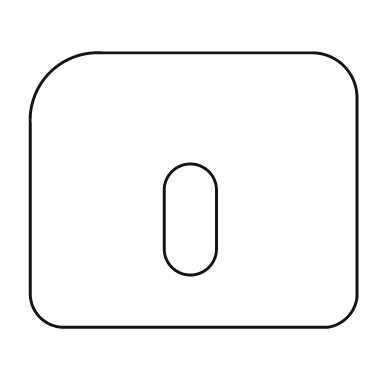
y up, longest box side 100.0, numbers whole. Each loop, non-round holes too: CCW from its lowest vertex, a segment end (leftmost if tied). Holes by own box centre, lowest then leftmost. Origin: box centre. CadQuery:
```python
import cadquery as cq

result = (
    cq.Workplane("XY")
    .moveTo(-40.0, -42.0)
    .lineTo(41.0, -42.0)
    .threePointArc((47.0, -39.0), (50.0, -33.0))
    .lineTo(50.0, 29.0)
    .threePointArc((46.0, 38.0), (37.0, 42.0))
    .lineTo(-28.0, 42.0)
    .threePointArc((-44.0, 36.0), (-50.0, 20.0))
    .lineTo(-50.0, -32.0)
    .threePointArc((-47.0, -39.0), (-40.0, -42.0))
    .close()
    .moveTo(-9.0, -18.0)
    .threePointArc((-1.0, -26.0), (7.0, -18.0))
    .lineTo(7.0, 0.0)
    .threePointArc((-1.0, 8.0), (-9.0, 0.0))
    .close()
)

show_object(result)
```